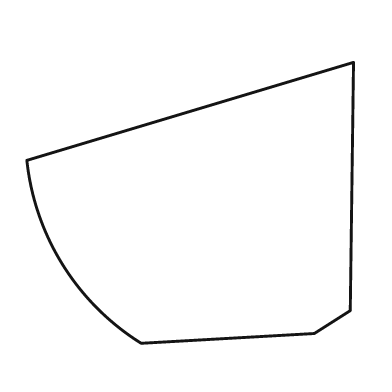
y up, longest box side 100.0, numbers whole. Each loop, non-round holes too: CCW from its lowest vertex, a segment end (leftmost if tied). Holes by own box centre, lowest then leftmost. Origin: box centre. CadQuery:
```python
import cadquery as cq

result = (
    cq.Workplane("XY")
    .moveTo(-15.0, -43.0)
    .lineTo(38.0, -40.0)
    .lineTo(49.0, -33.0)
    .lineTo(50.0, 43.0)
    .lineTo(-50.0, 13.0)
    .threePointArc((-39.0, -19.0), (-15.0, -43.0))
    .close()
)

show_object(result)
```